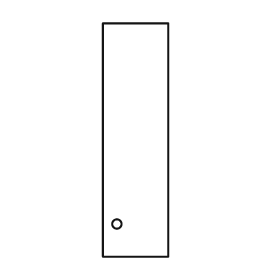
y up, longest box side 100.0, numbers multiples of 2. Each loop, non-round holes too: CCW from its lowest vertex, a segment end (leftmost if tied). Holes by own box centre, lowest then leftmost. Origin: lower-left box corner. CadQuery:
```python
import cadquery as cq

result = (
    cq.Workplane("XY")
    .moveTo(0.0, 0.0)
    .lineTo(28.0, 0.0)
    .lineTo(28.0, 100.0)
    .lineTo(0.0, 100.0)
    .close()
    .moveTo(6.0, 14.0)
    .circle(2.0)
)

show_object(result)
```